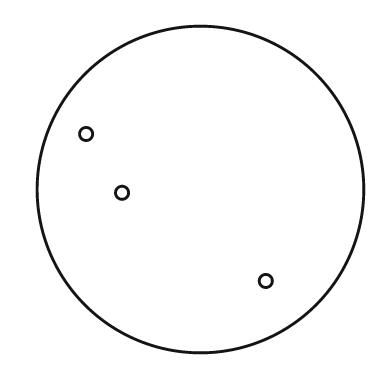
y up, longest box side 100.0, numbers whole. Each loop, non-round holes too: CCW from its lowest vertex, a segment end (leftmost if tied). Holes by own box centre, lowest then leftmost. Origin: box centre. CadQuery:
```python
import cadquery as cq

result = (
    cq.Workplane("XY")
    .moveTo(0.0, 0.0)
    .circle(50.0)
    .moveTo(20.0, -28.0)
    .circle(2.0)
    .moveTo(-24.0, -1.0)
    .circle(2.0)
    .moveTo(-35.0, 17.0)
    .circle(2.0)
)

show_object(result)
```